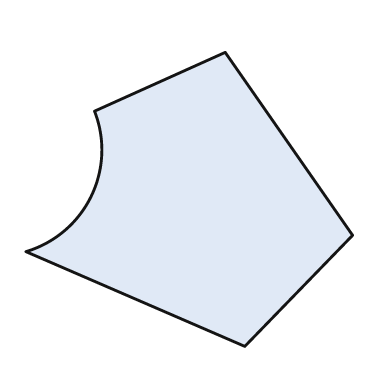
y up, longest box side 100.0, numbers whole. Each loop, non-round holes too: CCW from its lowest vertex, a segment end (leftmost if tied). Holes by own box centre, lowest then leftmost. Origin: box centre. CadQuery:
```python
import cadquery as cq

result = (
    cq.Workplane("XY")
    .moveTo(17.0, -45.0)
    .lineTo(50.0, -11.0)
    .lineTo(11.0, 45.0)
    .lineTo(-29.0, 27.0)
    .threePointArc((-30.0, 1.0), (-50.0, -16.0))
    .close()
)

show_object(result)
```